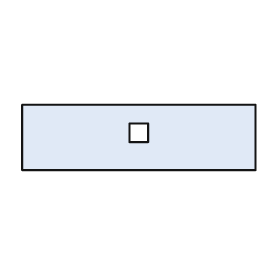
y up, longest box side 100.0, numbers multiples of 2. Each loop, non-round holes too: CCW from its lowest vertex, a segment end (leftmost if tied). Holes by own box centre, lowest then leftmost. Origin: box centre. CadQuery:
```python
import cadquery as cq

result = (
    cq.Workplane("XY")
    .moveTo(-50.0, -14.0)
    .lineTo(50.0, -14.0)
    .lineTo(50.0, 14.0)
    .lineTo(-50.0, 14.0)
    .close()
    .moveTo(-4.0, -2.0)
    .lineTo(4.0, -2.0)
    .lineTo(4.0, 6.0)
    .lineTo(-4.0, 6.0)
    .close()
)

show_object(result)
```